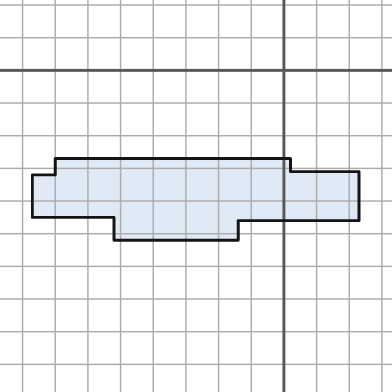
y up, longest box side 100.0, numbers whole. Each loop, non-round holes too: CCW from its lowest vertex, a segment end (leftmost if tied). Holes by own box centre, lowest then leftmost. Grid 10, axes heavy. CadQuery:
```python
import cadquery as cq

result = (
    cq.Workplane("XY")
    .moveTo(-52.0, -52.0)
    .lineTo(-14.0, -52.0)
    .lineTo(-14.0, -46.0)
    .lineTo(23.0, -46.0)
    .lineTo(23.0, -31.0)
    .lineTo(2.0, -31.0)
    .lineTo(2.0, -27.0)
    .lineTo(-70.0, -27.0)
    .lineTo(-70.0, -32.0)
    .lineTo(-77.0, -32.0)
    .lineTo(-77.0, -45.0)
    .lineTo(-52.0, -45.0)
    .close()
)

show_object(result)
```